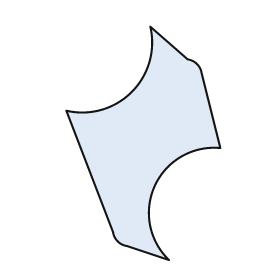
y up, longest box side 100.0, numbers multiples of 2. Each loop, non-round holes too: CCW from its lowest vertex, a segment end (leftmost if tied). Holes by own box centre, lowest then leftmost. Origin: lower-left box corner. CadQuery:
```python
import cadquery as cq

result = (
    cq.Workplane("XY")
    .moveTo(44.0, 0.0)
    .threePointArc((38.0, 32.0), (66.0, 48.0))
    .lineTo(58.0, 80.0)
    .threePointArc((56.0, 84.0), (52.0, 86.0))
    .lineTo(36.0, 100.0)
    .threePointArc((28.0, 72.0), (0.0, 64.0))
    .lineTo(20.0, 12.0)
    .threePointArc((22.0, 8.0), (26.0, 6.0))
    .close()
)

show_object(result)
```